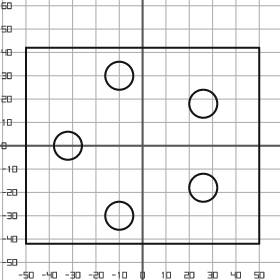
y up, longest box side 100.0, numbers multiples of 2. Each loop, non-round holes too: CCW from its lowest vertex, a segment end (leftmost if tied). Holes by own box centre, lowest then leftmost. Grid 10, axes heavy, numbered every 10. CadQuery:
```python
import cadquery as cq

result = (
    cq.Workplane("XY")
    .moveTo(-50.0, -42.0)
    .lineTo(50.0, -42.0)
    .lineTo(50.0, 42.0)
    .lineTo(-50.0, 42.0)
    .close()
    .moveTo(-10.0, -30.0)
    .circle(6.0)
    .moveTo(26.0, -18.0)
    .circle(6.0)
    .moveTo(-32.0, 0.0)
    .circle(6.0)
    .moveTo(26.0, 18.0)
    .circle(6.0)
    .moveTo(-10.0, 30.0)
    .circle(6.0)
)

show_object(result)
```